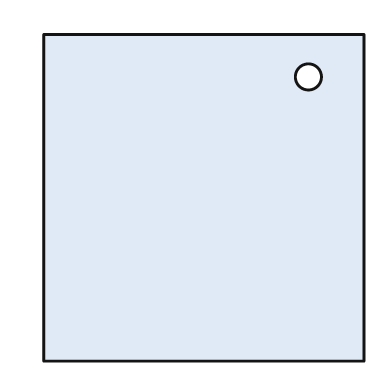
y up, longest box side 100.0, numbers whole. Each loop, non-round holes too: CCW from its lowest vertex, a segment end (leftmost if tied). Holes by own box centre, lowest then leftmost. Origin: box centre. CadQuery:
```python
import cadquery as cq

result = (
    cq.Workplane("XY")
    .moveTo(-49.0, -50.0)
    .lineTo(49.0, -50.0)
    .lineTo(49.0, 50.0)
    .lineTo(-49.0, 50.0)
    .close()
    .moveTo(32.0, 37.0)
    .circle(4.0)
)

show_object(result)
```